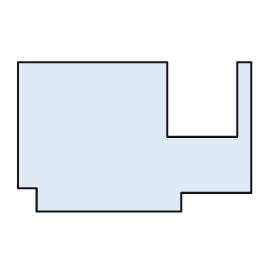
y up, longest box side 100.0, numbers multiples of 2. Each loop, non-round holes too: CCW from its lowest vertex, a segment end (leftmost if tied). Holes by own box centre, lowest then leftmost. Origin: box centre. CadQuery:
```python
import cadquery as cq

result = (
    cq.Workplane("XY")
    .moveTo(-42.0, -32.0)
    .lineTo(20.0, -32.0)
    .lineTo(20.0, -24.0)
    .lineTo(50.0, -24.0)
    .lineTo(50.0, 32.0)
    .lineTo(44.0, 32.0)
    .lineTo(44.0, 0.0)
    .lineTo(14.0, 0.0)
    .lineTo(14.0, 32.0)
    .lineTo(-50.0, 32.0)
    .lineTo(-50.0, -22.0)
    .lineTo(-42.0, -22.0)
    .close()
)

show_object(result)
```